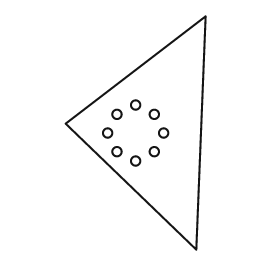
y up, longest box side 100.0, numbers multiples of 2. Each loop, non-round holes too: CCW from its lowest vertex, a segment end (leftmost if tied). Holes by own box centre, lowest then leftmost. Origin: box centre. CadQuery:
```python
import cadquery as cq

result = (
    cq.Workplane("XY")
    .moveTo(26.0, -50.0)
    .lineTo(30.0, 50.0)
    .lineTo(-30.0, 4.0)
    .close()
    .moveTo(0.0, -12.0)
    .circle(2.0)
    .moveTo(-8.0, -8.0)
    .circle(2.0)
    .moveTo(8.0, -8.0)
    .circle(2.0)
    .moveTo(-12.0, 0.0)
    .circle(2.0)
    .moveTo(12.0, 0.0)
    .circle(2.0)
    .moveTo(-8.0, 8.0)
    .circle(2.0)
    .moveTo(8.0, 8.0)
    .circle(2.0)
    .moveTo(0.0, 12.0)
    .circle(2.0)
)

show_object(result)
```